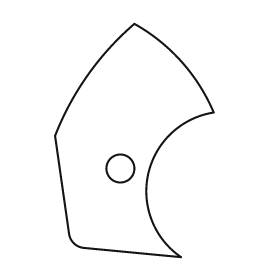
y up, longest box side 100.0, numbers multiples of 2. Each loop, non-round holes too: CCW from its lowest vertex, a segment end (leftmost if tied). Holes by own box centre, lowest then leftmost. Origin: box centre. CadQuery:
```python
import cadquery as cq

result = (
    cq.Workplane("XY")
    .moveTo(20.0, -50.0)
    .threePointArc((6.0, -14.0), (34.0, 12.0))
    .threePointArc((20.0, 34.0), (0.0, 50.0))
    .threePointArc((-20.0, 28.0), (-34.0, 2.0))
    .lineTo(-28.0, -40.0)
    .threePointArc((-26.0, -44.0), (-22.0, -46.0))
    .close()
    .moveTo(-6.0, -12.0)
    .circle(6.0)
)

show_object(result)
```